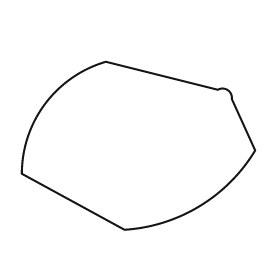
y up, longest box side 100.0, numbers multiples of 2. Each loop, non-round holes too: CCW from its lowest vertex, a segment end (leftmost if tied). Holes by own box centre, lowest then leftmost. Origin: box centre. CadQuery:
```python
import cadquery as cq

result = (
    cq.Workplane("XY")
    .moveTo(-6.0, -36.0)
    .threePointArc((26.0, -26.0), (50.0, -2.0))
    .lineTo(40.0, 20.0)
    .threePointArc((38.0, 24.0), (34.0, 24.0))
    .lineTo(-14.0, 36.0)
    .threePointArc((-40.0, 18.0), (-50.0, -12.0))
    .close()
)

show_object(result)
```